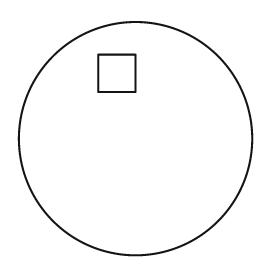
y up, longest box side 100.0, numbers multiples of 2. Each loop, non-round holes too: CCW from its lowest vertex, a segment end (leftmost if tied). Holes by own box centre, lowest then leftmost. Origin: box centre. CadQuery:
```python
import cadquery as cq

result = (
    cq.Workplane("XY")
    .moveTo(0.0, 0.0)
    .circle(50.0)
    .moveTo(-16.0, 20.0)
    .lineTo(0.0, 20.0)
    .lineTo(0.0, 36.0)
    .lineTo(-16.0, 36.0)
    .close()
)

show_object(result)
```